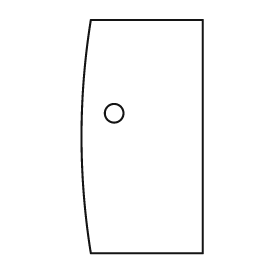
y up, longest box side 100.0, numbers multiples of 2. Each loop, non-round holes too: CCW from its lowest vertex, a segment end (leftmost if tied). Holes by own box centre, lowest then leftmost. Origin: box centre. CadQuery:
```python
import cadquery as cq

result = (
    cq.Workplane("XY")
    .moveTo(-22.0, -50.0)
    .lineTo(26.0, -50.0)
    .lineTo(26.0, 50.0)
    .lineTo(-22.0, 50.0)
    .threePointArc((-26.0, 0.0), (-22.0, -50.0))
    .close()
    .moveTo(-12.0, 10.0)
    .circle(4.0)
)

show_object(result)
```